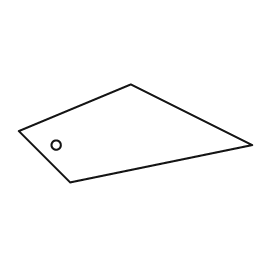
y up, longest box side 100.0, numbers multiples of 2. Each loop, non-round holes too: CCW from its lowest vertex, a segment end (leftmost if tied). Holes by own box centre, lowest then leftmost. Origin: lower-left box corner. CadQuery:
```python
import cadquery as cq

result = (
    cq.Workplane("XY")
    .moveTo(22.0, 0.0)
    .lineTo(100.0, 16.0)
    .lineTo(48.0, 42.0)
    .lineTo(0.0, 22.0)
    .close()
    .moveTo(16.0, 16.0)
    .circle(2.0)
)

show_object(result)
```